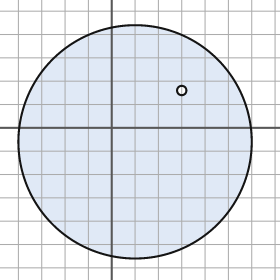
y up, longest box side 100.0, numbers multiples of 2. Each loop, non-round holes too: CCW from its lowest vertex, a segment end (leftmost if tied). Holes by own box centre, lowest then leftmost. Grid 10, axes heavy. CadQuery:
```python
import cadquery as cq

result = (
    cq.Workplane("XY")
    .moveTo(10.0, -6.0)
    .circle(50.0)
    .moveTo(30.0, 16.0)
    .circle(2.0)
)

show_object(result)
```